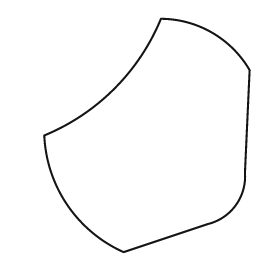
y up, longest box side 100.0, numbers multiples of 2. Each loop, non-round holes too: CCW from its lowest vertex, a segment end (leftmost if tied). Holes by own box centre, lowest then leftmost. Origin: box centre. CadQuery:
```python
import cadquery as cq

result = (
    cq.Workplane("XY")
    .moveTo(-10.0, -50.0)
    .lineTo(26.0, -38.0)
    .threePointArc((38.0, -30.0), (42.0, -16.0))
    .lineTo(44.0, 28.0)
    .threePointArc((28.0, 44.0), (6.0, 50.0))
    .threePointArc((-14.0, 20.0), (-44.0, 0.0))
    .threePointArc((-34.0, -30.0), (-10.0, -50.0))
    .close()
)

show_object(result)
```